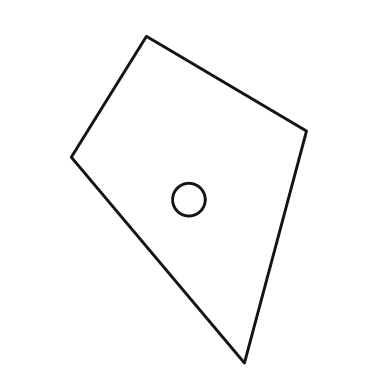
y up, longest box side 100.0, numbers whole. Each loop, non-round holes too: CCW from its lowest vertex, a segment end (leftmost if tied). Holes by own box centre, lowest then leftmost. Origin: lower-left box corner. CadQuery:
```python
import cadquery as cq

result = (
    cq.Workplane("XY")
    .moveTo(53.0, 0.0)
    .lineTo(72.0, 71.0)
    .lineTo(23.0, 100.0)
    .lineTo(0.0, 63.0)
    .close()
    .moveTo(36.0, 50.0)
    .circle(5.0)
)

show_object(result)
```